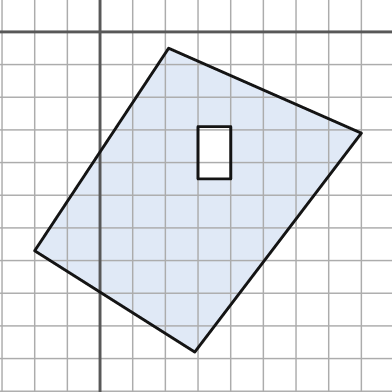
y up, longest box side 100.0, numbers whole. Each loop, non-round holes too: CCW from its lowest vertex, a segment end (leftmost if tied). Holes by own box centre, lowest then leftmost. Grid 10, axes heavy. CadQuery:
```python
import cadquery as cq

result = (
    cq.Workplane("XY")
    .moveTo(29.0, -98.0)
    .lineTo(80.0, -31.0)
    .lineTo(21.0, -5.0)
    .lineTo(-20.0, -67.0)
    .close()
    .moveTo(30.0, -45.0)
    .lineTo(40.0, -45.0)
    .lineTo(40.0, -29.0)
    .lineTo(30.0, -29.0)
    .close()
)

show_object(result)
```